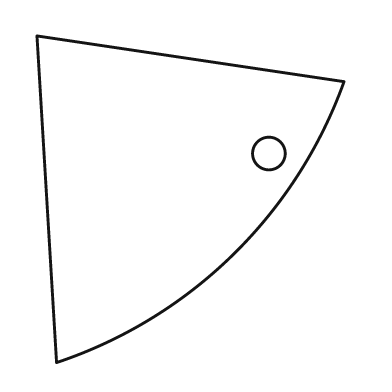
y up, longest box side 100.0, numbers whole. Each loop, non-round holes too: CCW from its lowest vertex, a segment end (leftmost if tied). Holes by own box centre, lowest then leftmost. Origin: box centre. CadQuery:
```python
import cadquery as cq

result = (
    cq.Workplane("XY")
    .moveTo(-41.0, -50.0)
    .threePointArc((13.0, -17.0), (47.0, 36.0))
    .lineTo(-47.0, 50.0)
    .close()
    .moveTo(24.0, 14.0)
    .circle(5.0)
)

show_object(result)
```